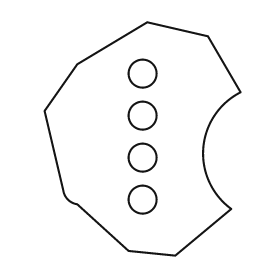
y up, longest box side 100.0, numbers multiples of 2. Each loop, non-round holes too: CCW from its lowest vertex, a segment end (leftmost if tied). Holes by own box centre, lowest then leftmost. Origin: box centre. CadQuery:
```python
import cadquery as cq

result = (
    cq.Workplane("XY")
    .moveTo(14.0, -50.0)
    .lineTo(38.0, -30.0)
    .threePointArc((26.0, -4.0), (42.0, 20.0))
    .lineTo(28.0, 44.0)
    .lineTo(2.0, 50.0)
    .lineTo(-28.0, 32.0)
    .lineTo(-42.0, 12.0)
    .lineTo(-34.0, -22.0)
    .threePointArc((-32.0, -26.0), (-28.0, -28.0))
    .lineTo(-6.0, -48.0)
    .close()
    .moveTo(0.0, -26.0)
    .circle(6.0)
    .moveTo(0.0, -8.0)
    .circle(6.0)
    .moveTo(0.0, 10.0)
    .circle(6.0)
    .moveTo(0.0, 28.0)
    .circle(6.0)
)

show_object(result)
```